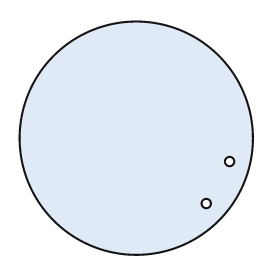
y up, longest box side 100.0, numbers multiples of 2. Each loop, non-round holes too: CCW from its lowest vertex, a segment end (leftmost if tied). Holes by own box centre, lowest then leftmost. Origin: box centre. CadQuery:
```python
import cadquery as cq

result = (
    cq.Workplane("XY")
    .moveTo(0.0, 0.0)
    .circle(50.0)
    .moveTo(30.0, -28.0)
    .circle(2.0)
    .moveTo(40.0, -10.0)
    .circle(2.0)
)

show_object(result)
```